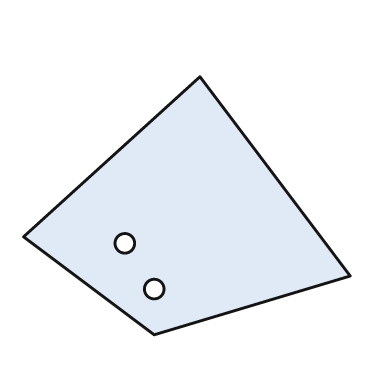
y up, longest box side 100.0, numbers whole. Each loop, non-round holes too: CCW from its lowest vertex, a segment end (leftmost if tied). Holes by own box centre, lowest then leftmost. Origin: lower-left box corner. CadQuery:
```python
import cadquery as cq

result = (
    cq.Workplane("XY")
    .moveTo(40.0, 0.0)
    .lineTo(100.0, 18.0)
    .lineTo(54.0, 79.0)
    .lineTo(0.0, 30.0)
    .close()
    .moveTo(40.0, 14.0)
    .circle(3.0)
    .moveTo(31.0, 28.0)
    .circle(3.0)
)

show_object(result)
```